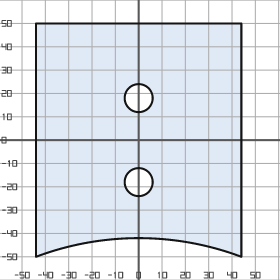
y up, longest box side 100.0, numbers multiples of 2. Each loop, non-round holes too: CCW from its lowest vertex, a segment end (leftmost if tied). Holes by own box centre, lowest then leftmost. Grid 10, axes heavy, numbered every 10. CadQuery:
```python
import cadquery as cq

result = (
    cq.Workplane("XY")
    .moveTo(-44.0, -50.0)
    .threePointArc((0.0, -42.0), (44.0, -50.0))
    .lineTo(44.0, 50.0)
    .lineTo(-44.0, 50.0)
    .close()
    .moveTo(0.0, -18.0)
    .circle(6.0)
    .moveTo(0.0, 18.0)
    .circle(6.0)
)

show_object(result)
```